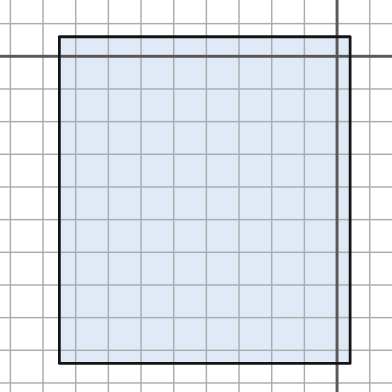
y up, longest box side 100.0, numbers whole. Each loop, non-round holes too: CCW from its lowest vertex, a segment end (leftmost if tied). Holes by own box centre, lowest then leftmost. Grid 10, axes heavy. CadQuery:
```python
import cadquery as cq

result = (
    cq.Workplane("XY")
    .moveTo(-85.0, -94.0)
    .lineTo(4.0, -94.0)
    .lineTo(4.0, 6.0)
    .lineTo(-85.0, 6.0)
    .close()
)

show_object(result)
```